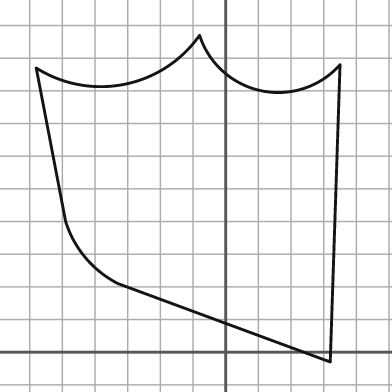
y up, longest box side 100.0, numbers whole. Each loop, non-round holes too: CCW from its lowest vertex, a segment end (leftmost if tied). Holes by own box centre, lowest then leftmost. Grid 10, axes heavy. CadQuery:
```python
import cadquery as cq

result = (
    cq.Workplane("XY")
    .moveTo(32.0, -3.0)
    .lineTo(35.0, 88.0)
    .threePointArc((11.0, 80.0), (-8.0, 97.0))
    .threePointArc((-31.0, 82.0), (-58.0, 87.0))
    .lineTo(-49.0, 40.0)
    .threePointArc((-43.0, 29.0), (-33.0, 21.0))
    .close()
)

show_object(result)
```